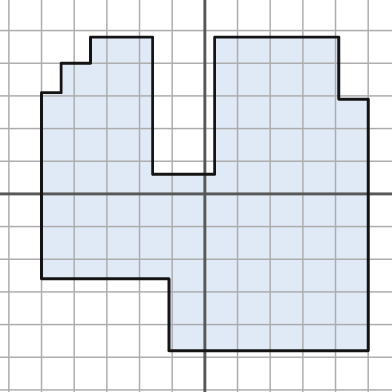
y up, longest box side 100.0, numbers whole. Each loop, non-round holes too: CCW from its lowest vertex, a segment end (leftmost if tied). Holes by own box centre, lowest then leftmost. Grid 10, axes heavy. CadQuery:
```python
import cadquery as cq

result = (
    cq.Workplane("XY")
    .moveTo(-11.0, -48.0)
    .lineTo(50.0, -48.0)
    .lineTo(50.0, 29.0)
    .lineTo(41.0, 29.0)
    .lineTo(41.0, 48.0)
    .lineTo(3.0, 48.0)
    .lineTo(3.0, 6.0)
    .lineTo(-16.0, 6.0)
    .lineTo(-16.0, 48.0)
    .lineTo(-35.0, 48.0)
    .lineTo(-35.0, 40.0)
    .lineTo(-44.0, 40.0)
    .lineTo(-44.0, 31.0)
    .lineTo(-50.0, 31.0)
    .lineTo(-50.0, -26.0)
    .lineTo(-11.0, -26.0)
    .close()
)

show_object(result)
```